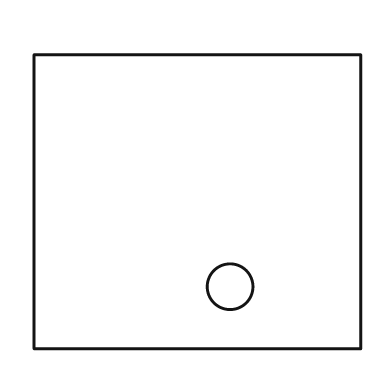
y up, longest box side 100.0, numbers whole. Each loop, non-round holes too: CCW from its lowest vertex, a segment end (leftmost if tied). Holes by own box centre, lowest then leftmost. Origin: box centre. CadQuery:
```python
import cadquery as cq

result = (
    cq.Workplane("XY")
    .moveTo(-50.0, -45.0)
    .lineTo(50.0, -45.0)
    .lineTo(50.0, 45.0)
    .lineTo(-50.0, 45.0)
    .close()
    .moveTo(10.0, -26.0)
    .circle(7.0)
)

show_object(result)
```